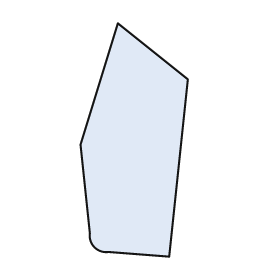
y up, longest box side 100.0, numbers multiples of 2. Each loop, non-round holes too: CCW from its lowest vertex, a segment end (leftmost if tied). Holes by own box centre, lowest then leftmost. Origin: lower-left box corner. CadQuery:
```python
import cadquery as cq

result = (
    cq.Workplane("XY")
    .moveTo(38.0, 0.0)
    .lineTo(46.0, 76.0)
    .lineTo(16.0, 100.0)
    .lineTo(0.0, 48.0)
    .lineTo(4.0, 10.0)
    .threePointArc((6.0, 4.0), (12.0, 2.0))
    .close()
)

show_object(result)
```